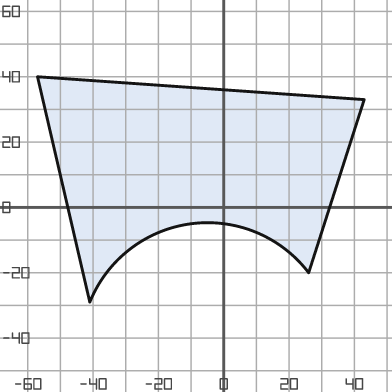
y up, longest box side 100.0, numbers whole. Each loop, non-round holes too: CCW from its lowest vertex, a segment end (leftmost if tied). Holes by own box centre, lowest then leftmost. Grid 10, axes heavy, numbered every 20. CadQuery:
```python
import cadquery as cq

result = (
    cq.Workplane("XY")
    .moveTo(-41.0, -29.0)
    .threePointArc((-10.0, -5.0), (26.0, -20.0))
    .lineTo(43.0, 33.0)
    .lineTo(-57.0, 40.0)
    .close()
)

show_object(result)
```